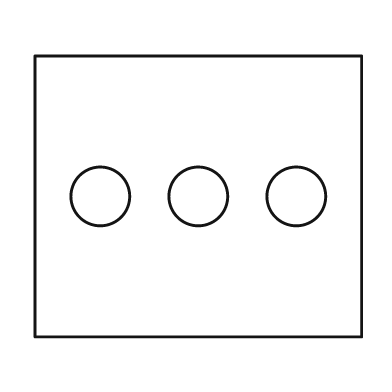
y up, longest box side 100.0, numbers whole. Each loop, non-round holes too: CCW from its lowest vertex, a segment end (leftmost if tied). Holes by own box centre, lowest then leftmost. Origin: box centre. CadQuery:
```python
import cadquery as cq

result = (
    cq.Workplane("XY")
    .moveTo(-50.0, -43.0)
    .lineTo(50.0, -43.0)
    .lineTo(50.0, 43.0)
    .lineTo(-50.0, 43.0)
    .close()
    .moveTo(-30.0, 0.0)
    .circle(9.0)
    .moveTo(0.0, 0.0)
    .circle(9.0)
    .moveTo(30.0, 0.0)
    .circle(9.0)
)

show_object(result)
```